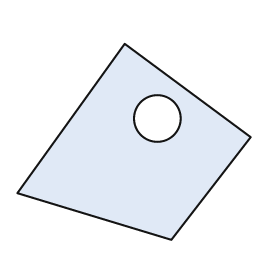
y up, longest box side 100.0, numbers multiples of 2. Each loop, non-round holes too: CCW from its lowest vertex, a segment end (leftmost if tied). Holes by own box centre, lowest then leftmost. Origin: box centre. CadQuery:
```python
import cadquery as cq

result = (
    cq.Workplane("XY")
    .moveTo(16.0, -42.0)
    .lineTo(50.0, 2.0)
    .lineTo(-4.0, 42.0)
    .lineTo(-50.0, -22.0)
    .close()
    .moveTo(10.0, 10.0)
    .circle(10.0)
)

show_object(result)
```